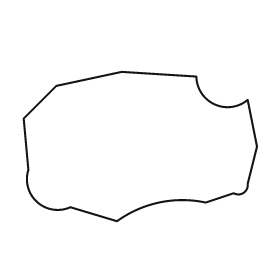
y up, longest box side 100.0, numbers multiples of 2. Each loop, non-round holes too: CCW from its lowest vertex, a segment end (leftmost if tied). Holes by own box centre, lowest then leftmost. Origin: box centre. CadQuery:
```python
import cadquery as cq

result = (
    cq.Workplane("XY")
    .moveTo(-10.0, -32.0)
    .threePointArc((8.0, -24.0), (28.0, -24.0))
    .lineTo(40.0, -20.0)
    .threePointArc((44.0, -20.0), (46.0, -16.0))
    .lineTo(50.0, 0.0)
    .lineTo(46.0, 20.0)
    .threePointArc((32.0, 18.0), (24.0, 30.0))
    .lineTo(-8.0, 32.0)
    .lineTo(-36.0, 26.0)
    .lineTo(-50.0, 12.0)
    .lineTo(-48.0, -10.0)
    .threePointArc((-44.0, -24.0), (-30.0, -26.0))
    .close()
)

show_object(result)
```